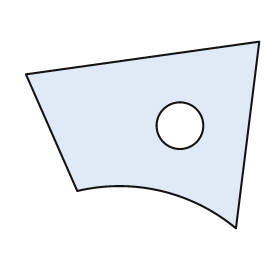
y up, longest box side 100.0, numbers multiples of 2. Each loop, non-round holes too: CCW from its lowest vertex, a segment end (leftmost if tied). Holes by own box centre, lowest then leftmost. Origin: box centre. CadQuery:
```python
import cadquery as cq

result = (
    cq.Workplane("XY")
    .moveTo(40.0, -40.0)
    .lineTo(50.0, 40.0)
    .lineTo(-50.0, 26.0)
    .lineTo(-28.0, -24.0)
    .threePointArc((8.0, -24.0), (40.0, -40.0))
    .close()
    .moveTo(16.0, 4.0)
    .circle(10.0)
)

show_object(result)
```